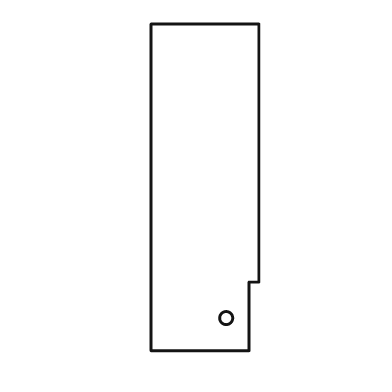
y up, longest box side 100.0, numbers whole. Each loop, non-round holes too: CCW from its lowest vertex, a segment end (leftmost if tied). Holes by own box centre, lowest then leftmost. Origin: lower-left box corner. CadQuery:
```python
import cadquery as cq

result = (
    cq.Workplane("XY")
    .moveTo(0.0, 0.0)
    .lineTo(30.0, 0.0)
    .lineTo(30.0, 21.0)
    .lineTo(33.0, 21.0)
    .lineTo(33.0, 100.0)
    .lineTo(0.0, 100.0)
    .close()
    .moveTo(23.0, 10.0)
    .circle(2.0)
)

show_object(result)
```